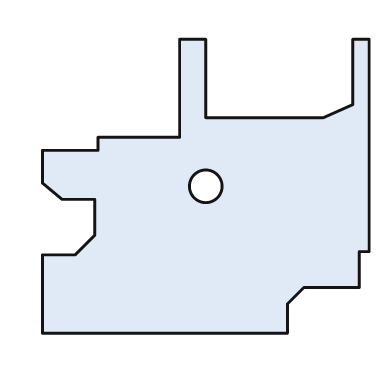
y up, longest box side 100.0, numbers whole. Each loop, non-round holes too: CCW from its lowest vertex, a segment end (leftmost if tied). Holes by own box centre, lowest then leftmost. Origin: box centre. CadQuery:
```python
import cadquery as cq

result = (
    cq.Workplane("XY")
    .moveTo(-50.0, -45.0)
    .lineTo(25.0, -45.0)
    .lineTo(25.0, -36.0)
    .lineTo(30.0, -31.0)
    .lineTo(47.0, -31.0)
    .lineTo(47.0, -20.0)
    .lineTo(50.0, -20.0)
    .lineTo(50.0, 45.0)
    .lineTo(45.0, 45.0)
    .lineTo(45.0, 25.0)
    .lineTo(36.0, 21.0)
    .lineTo(0.0, 21.0)
    .lineTo(0.0, 45.0)
    .lineTo(-8.0, 45.0)
    .lineTo(-8.0, 15.0)
    .lineTo(-33.0, 15.0)
    .lineTo(-33.0, 11.0)
    .lineTo(-50.0, 11.0)
    .lineTo(-50.0, 1.0)
    .lineTo(-44.0, -4.0)
    .lineTo(-34.0, -4.0)
    .lineTo(-34.0, -15.0)
    .lineTo(-40.0, -21.0)
    .lineTo(-50.0, -21.0)
    .close()
    .moveTo(0.0, 0.0)
    .circle(5.0)
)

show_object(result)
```